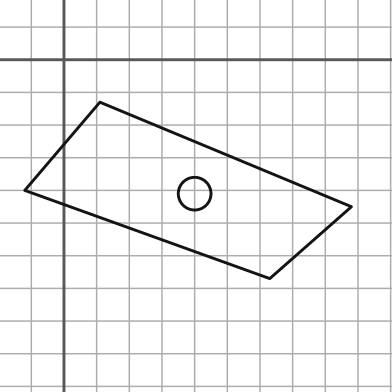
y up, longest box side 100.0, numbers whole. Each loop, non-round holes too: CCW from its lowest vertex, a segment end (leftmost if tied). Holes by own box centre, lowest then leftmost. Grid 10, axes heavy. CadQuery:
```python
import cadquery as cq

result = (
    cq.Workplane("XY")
    .moveTo(63.0, -67.0)
    .lineTo(88.0, -45.0)
    .lineTo(11.0, -13.0)
    .lineTo(-12.0, -40.0)
    .close()
    .moveTo(40.0, -41.0)
    .circle(5.0)
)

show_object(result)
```